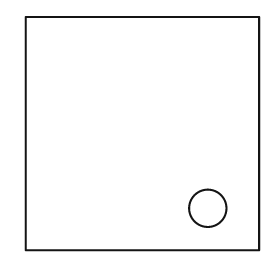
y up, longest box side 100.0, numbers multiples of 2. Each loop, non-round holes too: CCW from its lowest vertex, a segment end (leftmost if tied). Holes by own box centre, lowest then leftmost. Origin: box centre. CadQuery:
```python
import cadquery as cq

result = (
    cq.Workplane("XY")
    .moveTo(-50.0, -50.0)
    .lineTo(50.0, -50.0)
    .lineTo(50.0, 50.0)
    .lineTo(-50.0, 50.0)
    .close()
    .moveTo(28.0, -32.0)
    .circle(8.0)
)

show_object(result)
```